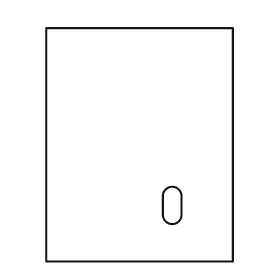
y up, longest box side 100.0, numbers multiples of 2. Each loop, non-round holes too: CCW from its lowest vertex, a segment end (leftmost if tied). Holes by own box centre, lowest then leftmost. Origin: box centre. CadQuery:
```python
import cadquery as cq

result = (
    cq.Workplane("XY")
    .moveTo(-40.0, -50.0)
    .lineTo(40.0, -50.0)
    .lineTo(40.0, 50.0)
    .lineTo(-40.0, 50.0)
    .close()
    .moveTo(10.0, -30.0)
    .threePointArc((14.0, -34.0), (18.0, -30.0))
    .lineTo(18.0, -22.0)
    .threePointArc((14.0, -18.0), (10.0, -22.0))
    .close()
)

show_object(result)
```